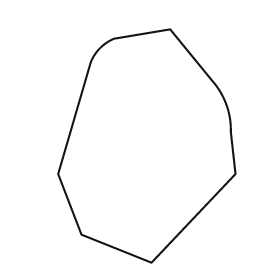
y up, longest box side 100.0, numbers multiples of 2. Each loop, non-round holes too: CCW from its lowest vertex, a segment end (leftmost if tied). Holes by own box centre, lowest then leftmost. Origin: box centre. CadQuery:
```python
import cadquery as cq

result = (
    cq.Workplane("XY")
    .moveTo(2.0, -50.0)
    .lineTo(38.0, -12.0)
    .lineTo(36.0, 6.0)
    .threePointArc((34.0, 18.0), (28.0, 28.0))
    .lineTo(10.0, 50.0)
    .lineTo(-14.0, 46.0)
    .threePointArc((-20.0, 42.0), (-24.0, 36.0))
    .lineTo(-38.0, -12.0)
    .lineTo(-28.0, -38.0)
    .close()
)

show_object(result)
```